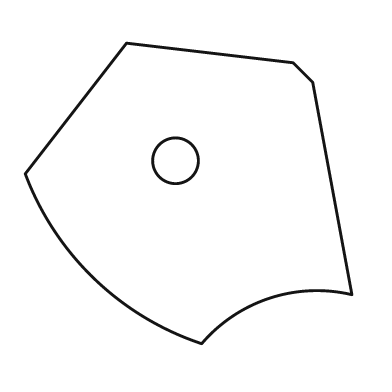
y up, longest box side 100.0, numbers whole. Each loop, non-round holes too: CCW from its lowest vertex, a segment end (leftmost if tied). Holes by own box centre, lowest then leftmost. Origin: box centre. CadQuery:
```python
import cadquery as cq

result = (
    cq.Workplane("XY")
    .moveTo(4.0, -46.0)
    .threePointArc((25.0, -32.0), (50.0, -31.0))
    .lineTo(38.0, 34.0)
    .lineTo(32.0, 40.0)
    .lineTo(-19.0, 46.0)
    .lineTo(-50.0, 6.0)
    .threePointArc((-29.0, -26.0), (4.0, -46.0))
    .close()
    .moveTo(-4.0, 10.0)
    .circle(7.0)
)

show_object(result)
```